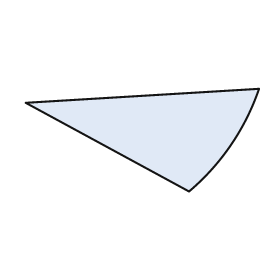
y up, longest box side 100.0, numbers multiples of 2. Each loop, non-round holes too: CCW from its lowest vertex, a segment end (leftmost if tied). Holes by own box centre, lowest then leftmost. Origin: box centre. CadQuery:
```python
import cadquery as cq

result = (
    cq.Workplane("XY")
    .moveTo(20.0, -22.0)
    .threePointArc((38.0, -2.0), (50.0, 22.0))
    .lineTo(-50.0, 16.0)
    .close()
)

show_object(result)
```